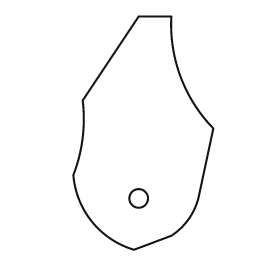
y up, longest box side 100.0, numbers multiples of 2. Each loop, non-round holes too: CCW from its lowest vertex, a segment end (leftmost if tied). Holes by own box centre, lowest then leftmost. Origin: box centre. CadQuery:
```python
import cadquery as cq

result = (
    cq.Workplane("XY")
    .moveTo(-4.0, -50.0)
    .lineTo(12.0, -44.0)
    .threePointArc((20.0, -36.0), (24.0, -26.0))
    .lineTo(30.0, 2.0)
    .threePointArc((16.0, 24.0), (12.0, 50.0))
    .lineTo(-2.0, 50.0)
    .lineTo(-26.0, 14.0)
    .threePointArc((-26.0, -2.0), (-30.0, -18.0))
    .threePointArc((-22.0, -38.0), (-4.0, -50.0))
    .close()
    .moveTo(-2.0, -28.0)
    .circle(4.0)
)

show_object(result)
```